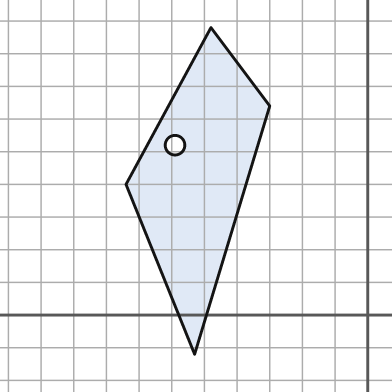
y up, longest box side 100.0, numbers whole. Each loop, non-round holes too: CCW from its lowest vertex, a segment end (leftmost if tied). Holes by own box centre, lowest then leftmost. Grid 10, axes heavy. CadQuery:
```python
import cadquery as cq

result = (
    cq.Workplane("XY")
    .moveTo(-53.0, -12.0)
    .lineTo(-30.0, 64.0)
    .lineTo(-48.0, 88.0)
    .lineTo(-74.0, 40.0)
    .close()
    .moveTo(-59.0, 52.0)
    .circle(3.0)
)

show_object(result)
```